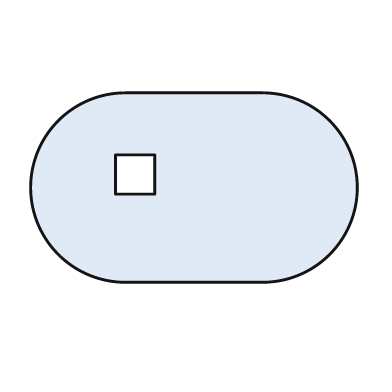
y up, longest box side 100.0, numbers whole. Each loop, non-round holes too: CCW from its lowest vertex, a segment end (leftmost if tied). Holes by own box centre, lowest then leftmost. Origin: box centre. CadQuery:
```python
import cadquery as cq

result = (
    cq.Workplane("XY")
    .moveTo(-21.0, -29.0)
    .lineTo(21.0, -29.0)
    .threePointArc((50.0, 0.0), (21.0, 29.0))
    .lineTo(-21.0, 29.0)
    .threePointArc((-50.0, 0.0), (-21.0, -29.0))
    .close()
    .moveTo(-24.0, -2.0)
    .lineTo(-12.0, -2.0)
    .lineTo(-12.0, 10.0)
    .lineTo(-24.0, 10.0)
    .close()
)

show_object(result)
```